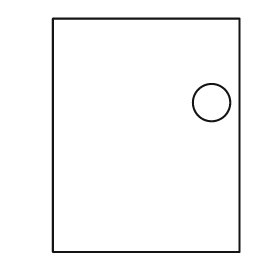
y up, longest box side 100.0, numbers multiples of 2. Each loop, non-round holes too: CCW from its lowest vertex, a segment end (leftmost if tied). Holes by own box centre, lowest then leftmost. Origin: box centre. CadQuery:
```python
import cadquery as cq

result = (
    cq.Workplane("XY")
    .moveTo(-40.0, -50.0)
    .lineTo(40.0, -50.0)
    .lineTo(40.0, 50.0)
    .lineTo(-40.0, 50.0)
    .close()
    .moveTo(28.0, 14.0)
    .circle(8.0)
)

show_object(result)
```